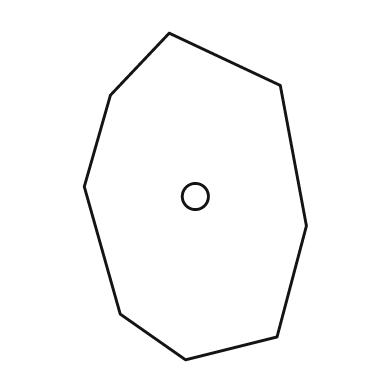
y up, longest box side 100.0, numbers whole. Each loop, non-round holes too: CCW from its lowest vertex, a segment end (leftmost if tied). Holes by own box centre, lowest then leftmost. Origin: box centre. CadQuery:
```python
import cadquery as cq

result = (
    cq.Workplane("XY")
    .moveTo(-3.0, -50.0)
    .lineTo(25.0, -43.0)
    .lineTo(34.0, -9.0)
    .lineTo(26.0, 34.0)
    .lineTo(-8.0, 50.0)
    .lineTo(-26.0, 31.0)
    .lineTo(-34.0, 3.0)
    .lineTo(-23.0, -36.0)
    .close()
    .moveTo(0.0, 0.0)
    .circle(4.0)
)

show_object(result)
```